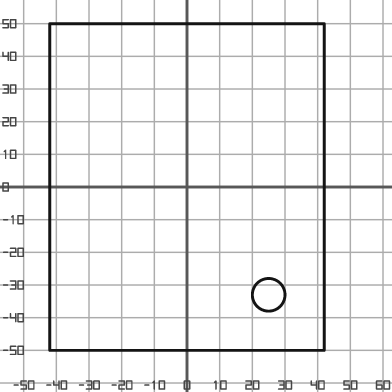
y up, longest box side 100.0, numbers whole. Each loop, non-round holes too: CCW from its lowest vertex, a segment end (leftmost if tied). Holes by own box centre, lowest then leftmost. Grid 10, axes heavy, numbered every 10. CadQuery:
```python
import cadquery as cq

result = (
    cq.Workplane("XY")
    .moveTo(-42.0, -50.0)
    .lineTo(42.0, -50.0)
    .lineTo(42.0, 50.0)
    .lineTo(-42.0, 50.0)
    .close()
    .moveTo(25.0, -33.0)
    .circle(5.0)
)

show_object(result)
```